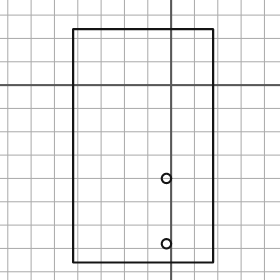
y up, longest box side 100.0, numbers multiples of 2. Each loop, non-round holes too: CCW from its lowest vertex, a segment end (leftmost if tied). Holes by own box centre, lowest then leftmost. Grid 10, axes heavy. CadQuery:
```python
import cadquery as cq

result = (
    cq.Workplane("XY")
    .moveTo(-42.0, -76.0)
    .lineTo(18.0, -76.0)
    .lineTo(18.0, 24.0)
    .lineTo(-42.0, 24.0)
    .close()
    .moveTo(-2.0, -68.0)
    .circle(2.0)
    .moveTo(-2.0, -40.0)
    .circle(2.0)
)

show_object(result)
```